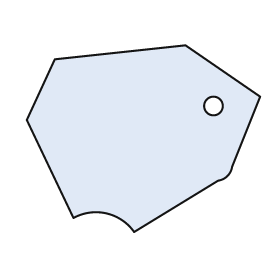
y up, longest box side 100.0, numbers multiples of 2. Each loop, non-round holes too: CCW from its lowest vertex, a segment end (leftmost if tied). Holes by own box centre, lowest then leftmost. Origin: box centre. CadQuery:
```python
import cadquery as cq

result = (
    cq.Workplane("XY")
    .moveTo(-4.0, -40.0)
    .lineTo(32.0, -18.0)
    .threePointArc((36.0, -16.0), (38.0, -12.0))
    .lineTo(50.0, 18.0)
    .lineTo(18.0, 40.0)
    .lineTo(-38.0, 34.0)
    .lineTo(-50.0, 8.0)
    .lineTo(-30.0, -34.0)
    .threePointArc((-16.0, -32.0), (-4.0, -40.0))
    .close()
    .moveTo(30.0, 14.0)
    .circle(4.0)
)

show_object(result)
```